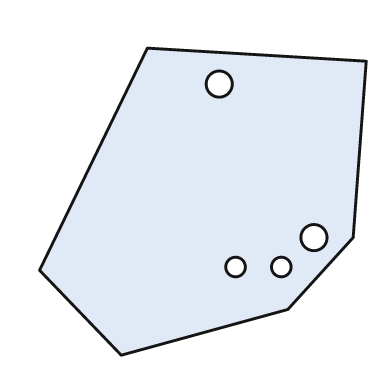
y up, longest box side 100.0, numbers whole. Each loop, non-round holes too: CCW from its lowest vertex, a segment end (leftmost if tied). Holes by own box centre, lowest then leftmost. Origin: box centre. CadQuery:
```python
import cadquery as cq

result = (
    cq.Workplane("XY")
    .moveTo(-25.0, -47.0)
    .lineTo(26.0, -33.0)
    .lineTo(46.0, -11.0)
    .lineTo(50.0, 43.0)
    .lineTo(-17.0, 47.0)
    .lineTo(-50.0, -21.0)
    .close()
    .moveTo(10.0, -20.0)
    .circle(3.0)
    .moveTo(24.0, -20.0)
    .circle(3.0)
    .moveTo(34.0, -11.0)
    .circle(4.0)
    .moveTo(5.0, 36.0)
    .circle(4.0)
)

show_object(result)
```